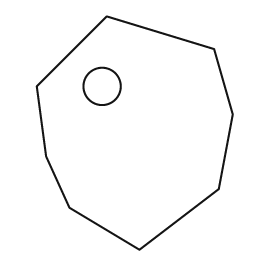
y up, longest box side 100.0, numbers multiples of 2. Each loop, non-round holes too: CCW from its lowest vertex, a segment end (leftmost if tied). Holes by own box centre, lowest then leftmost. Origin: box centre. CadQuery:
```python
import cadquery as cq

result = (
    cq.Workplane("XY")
    .moveTo(2.0, -50.0)
    .lineTo(36.0, -24.0)
    .lineTo(42.0, 8.0)
    .lineTo(34.0, 36.0)
    .lineTo(-12.0, 50.0)
    .lineTo(-42.0, 20.0)
    .lineTo(-38.0, -10.0)
    .lineTo(-28.0, -32.0)
    .close()
    .moveTo(-14.0, 20.0)
    .circle(8.0)
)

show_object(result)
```